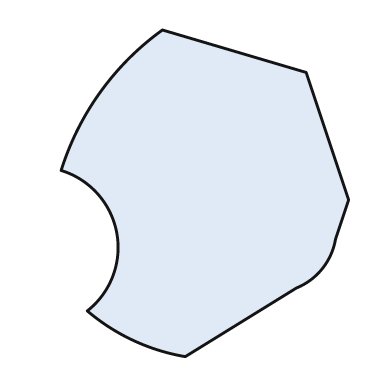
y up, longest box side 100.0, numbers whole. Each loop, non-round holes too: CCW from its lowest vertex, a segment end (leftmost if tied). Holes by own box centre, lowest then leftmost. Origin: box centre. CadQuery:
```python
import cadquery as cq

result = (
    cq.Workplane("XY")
    .moveTo(-6.0, -50.0)
    .lineTo(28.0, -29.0)
    .threePointArc((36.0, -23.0), (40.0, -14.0))
    .lineTo(44.0, -2.0)
    .lineTo(31.0, 37.0)
    .lineTo(-13.0, 50.0)
    .threePointArc((-32.0, 31.0), (-44.0, 7.0))
    .threePointArc((-27.0, -12.0), (-36.0, -36.0))
    .threePointArc((-22.0, -45.0), (-6.0, -50.0))
    .close()
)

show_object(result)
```